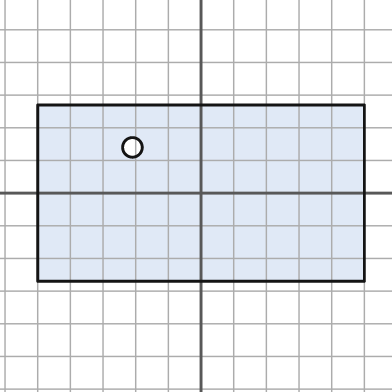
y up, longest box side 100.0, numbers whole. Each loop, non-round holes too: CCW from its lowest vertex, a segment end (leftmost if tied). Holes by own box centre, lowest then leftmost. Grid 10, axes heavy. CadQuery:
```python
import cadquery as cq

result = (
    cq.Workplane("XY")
    .moveTo(-50.0, -27.0)
    .lineTo(50.0, -27.0)
    .lineTo(50.0, 27.0)
    .lineTo(-50.0, 27.0)
    .close()
    .moveTo(-21.0, 14.0)
    .circle(3.0)
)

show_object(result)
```